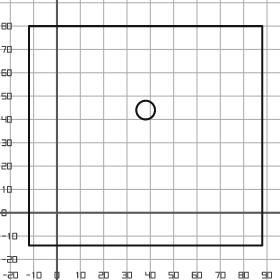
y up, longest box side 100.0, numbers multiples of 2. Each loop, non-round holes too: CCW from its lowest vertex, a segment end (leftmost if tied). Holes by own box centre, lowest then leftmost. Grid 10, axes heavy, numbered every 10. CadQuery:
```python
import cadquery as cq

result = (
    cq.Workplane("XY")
    .moveTo(-12.0, -14.0)
    .lineTo(88.0, -14.0)
    .lineTo(88.0, 80.0)
    .lineTo(-12.0, 80.0)
    .close()
    .moveTo(38.0, 44.0)
    .circle(4.0)
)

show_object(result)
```